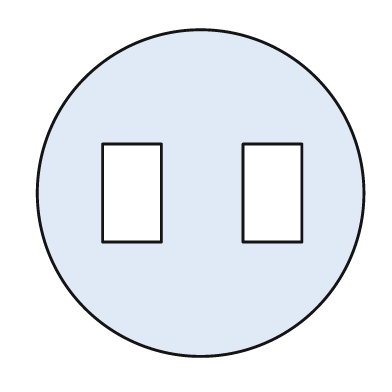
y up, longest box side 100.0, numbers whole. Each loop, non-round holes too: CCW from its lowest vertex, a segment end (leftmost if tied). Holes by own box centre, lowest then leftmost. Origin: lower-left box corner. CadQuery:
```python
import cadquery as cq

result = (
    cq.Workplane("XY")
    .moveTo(50.0, 50.0)
    .circle(50.0)
    .moveTo(20.0, 35.0)
    .lineTo(38.0, 35.0)
    .lineTo(38.0, 65.0)
    .lineTo(20.0, 65.0)
    .close()
    .moveTo(63.0, 35.0)
    .lineTo(81.0, 35.0)
    .lineTo(81.0, 65.0)
    .lineTo(63.0, 65.0)
    .close()
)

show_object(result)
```